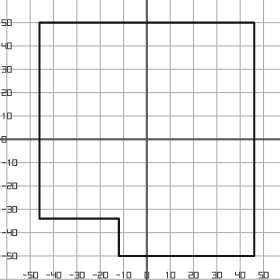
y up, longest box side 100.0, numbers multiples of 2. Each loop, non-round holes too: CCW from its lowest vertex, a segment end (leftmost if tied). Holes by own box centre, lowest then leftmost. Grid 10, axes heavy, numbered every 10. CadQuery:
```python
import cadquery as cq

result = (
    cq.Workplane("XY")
    .moveTo(-12.0, -50.0)
    .lineTo(46.0, -50.0)
    .lineTo(46.0, 50.0)
    .lineTo(-46.0, 50.0)
    .lineTo(-46.0, -34.0)
    .lineTo(-12.0, -34.0)
    .close()
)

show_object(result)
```